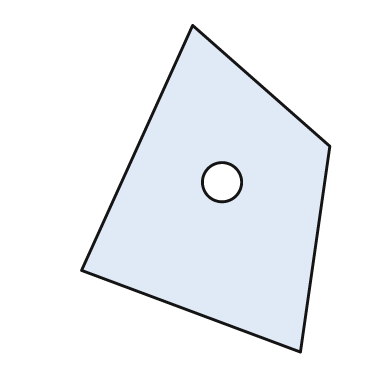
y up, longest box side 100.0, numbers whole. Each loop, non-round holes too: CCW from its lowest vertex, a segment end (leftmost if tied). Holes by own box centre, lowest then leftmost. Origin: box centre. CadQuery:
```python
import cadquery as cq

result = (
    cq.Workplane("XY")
    .moveTo(29.0, -50.0)
    .lineTo(38.0, 13.0)
    .lineTo(-4.0, 50.0)
    .lineTo(-38.0, -25.0)
    .close()
    .moveTo(5.0, 2.0)
    .circle(6.0)
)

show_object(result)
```